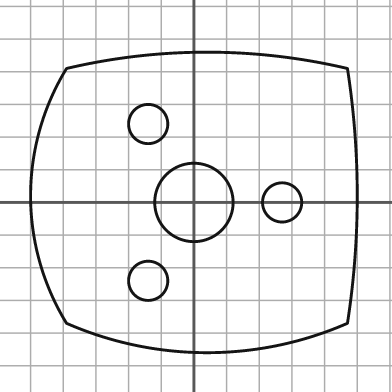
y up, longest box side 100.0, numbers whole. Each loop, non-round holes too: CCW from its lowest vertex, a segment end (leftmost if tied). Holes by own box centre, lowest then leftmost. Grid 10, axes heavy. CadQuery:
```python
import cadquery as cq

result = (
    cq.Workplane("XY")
    .moveTo(-39.0, -37.0)
    .threePointArc((4.0, -46.0), (47.0, -37.0))
    .threePointArc((50.0, 2.0), (47.0, 41.0))
    .threePointArc((4.0, 46.0), (-39.0, 41.0))
    .threePointArc((-50.0, 2.0), (-39.0, -37.0))
    .close()
    .moveTo(-14.0, -24.0)
    .circle(6.0)
    .moveTo(0.0, 0.0)
    .circle(12.0)
    .moveTo(27.0, 0.0)
    .circle(6.0)
    .moveTo(-14.0, 24.0)
    .circle(6.0)
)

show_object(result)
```